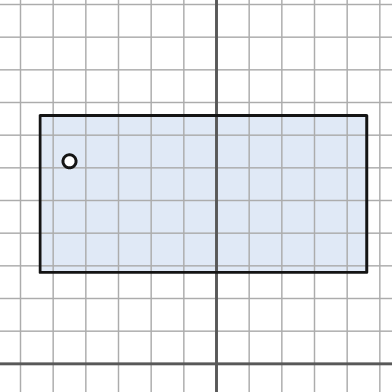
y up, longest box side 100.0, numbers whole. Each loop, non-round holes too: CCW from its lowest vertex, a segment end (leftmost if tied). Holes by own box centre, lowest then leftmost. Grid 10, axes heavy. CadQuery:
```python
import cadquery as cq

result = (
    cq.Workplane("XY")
    .moveTo(-54.0, 28.0)
    .lineTo(46.0, 28.0)
    .lineTo(46.0, 76.0)
    .lineTo(-54.0, 76.0)
    .close()
    .moveTo(-45.0, 62.0)
    .circle(2.0)
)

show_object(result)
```